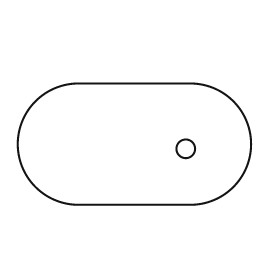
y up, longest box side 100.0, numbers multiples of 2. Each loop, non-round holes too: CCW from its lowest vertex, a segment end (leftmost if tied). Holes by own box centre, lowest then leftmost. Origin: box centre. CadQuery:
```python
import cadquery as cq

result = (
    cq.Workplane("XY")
    .moveTo(-24.0, -26.0)
    .lineTo(24.0, -26.0)
    .threePointArc((50.0, 0.0), (24.0, 26.0))
    .lineTo(-24.0, 26.0)
    .threePointArc((-50.0, 0.0), (-24.0, -26.0))
    .close()
    .moveTo(22.0, -2.0)
    .circle(4.0)
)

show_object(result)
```